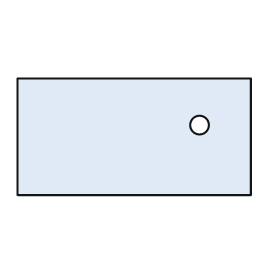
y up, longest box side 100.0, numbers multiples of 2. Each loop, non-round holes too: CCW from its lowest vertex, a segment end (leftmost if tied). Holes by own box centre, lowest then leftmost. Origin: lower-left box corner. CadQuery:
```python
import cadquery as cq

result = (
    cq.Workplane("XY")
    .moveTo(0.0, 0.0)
    .lineTo(100.0, 0.0)
    .lineTo(100.0, 50.0)
    .lineTo(0.0, 50.0)
    .close()
    .moveTo(78.0, 30.0)
    .circle(4.0)
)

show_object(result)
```